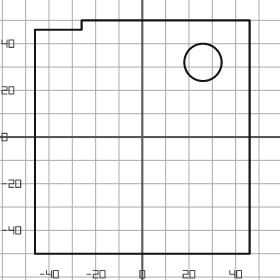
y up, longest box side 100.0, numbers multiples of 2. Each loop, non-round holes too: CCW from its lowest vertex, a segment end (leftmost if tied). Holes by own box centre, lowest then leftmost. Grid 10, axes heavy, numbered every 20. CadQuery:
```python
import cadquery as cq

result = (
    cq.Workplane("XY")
    .moveTo(-46.0, -50.0)
    .lineTo(46.0, -50.0)
    .lineTo(46.0, 50.0)
    .lineTo(-26.0, 50.0)
    .lineTo(-26.0, 46.0)
    .lineTo(-46.0, 46.0)
    .close()
    .moveTo(26.0, 32.0)
    .circle(8.0)
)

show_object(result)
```